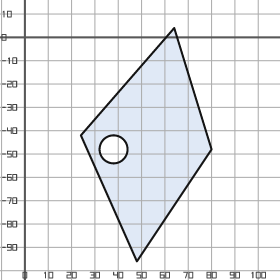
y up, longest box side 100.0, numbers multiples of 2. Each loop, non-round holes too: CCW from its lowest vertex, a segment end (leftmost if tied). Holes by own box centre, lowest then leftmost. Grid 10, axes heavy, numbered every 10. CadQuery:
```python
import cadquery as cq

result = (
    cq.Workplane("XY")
    .moveTo(48.0, -96.0)
    .lineTo(80.0, -48.0)
    .lineTo(64.0, 4.0)
    .lineTo(24.0, -42.0)
    .close()
    .moveTo(38.0, -48.0)
    .circle(6.0)
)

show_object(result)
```